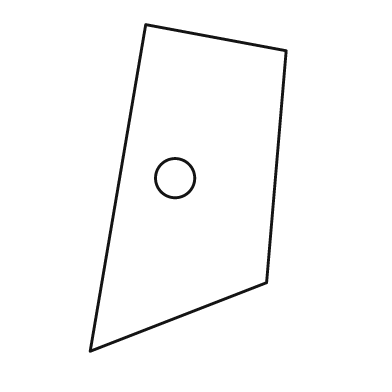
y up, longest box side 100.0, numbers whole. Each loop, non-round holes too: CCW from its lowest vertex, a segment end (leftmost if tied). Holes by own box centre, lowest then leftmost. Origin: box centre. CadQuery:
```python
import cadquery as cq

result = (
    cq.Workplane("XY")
    .moveTo(-30.0, -50.0)
    .lineTo(24.0, -29.0)
    .lineTo(30.0, 42.0)
    .lineTo(-13.0, 50.0)
    .close()
    .moveTo(-4.0, 3.0)
    .circle(6.0)
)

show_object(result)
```